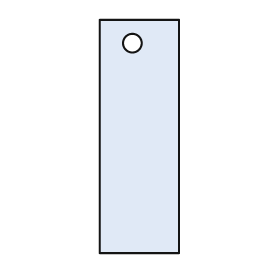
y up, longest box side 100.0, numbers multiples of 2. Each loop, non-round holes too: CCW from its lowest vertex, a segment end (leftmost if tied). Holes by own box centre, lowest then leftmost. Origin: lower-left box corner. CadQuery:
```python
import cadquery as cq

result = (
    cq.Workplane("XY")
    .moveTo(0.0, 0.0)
    .lineTo(34.0, 0.0)
    .lineTo(34.0, 100.0)
    .lineTo(0.0, 100.0)
    .close()
    .moveTo(14.0, 90.0)
    .circle(4.0)
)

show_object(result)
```